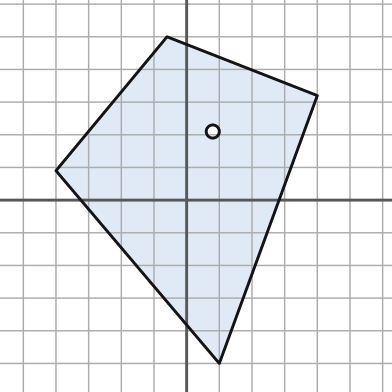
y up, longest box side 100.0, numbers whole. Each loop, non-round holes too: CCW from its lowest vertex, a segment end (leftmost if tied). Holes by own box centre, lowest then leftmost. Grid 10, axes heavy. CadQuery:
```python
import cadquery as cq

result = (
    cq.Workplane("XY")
    .moveTo(10.0, -50.0)
    .lineTo(40.0, 32.0)
    .lineTo(-6.0, 50.0)
    .lineTo(-40.0, 9.0)
    .close()
    .moveTo(8.0, 21.0)
    .circle(2.0)
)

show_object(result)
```